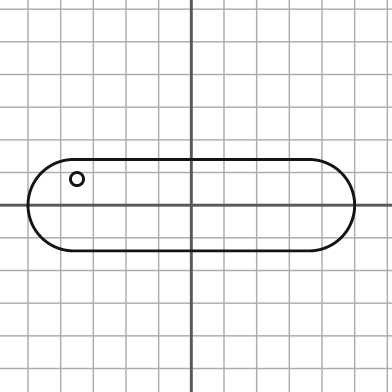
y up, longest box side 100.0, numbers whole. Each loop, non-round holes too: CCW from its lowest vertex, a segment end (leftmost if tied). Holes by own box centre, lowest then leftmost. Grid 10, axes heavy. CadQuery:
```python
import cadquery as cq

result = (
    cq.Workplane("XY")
    .moveTo(-36.0, -14.0)
    .lineTo(36.0, -14.0)
    .threePointArc((50.0, 0.0), (36.0, 14.0))
    .lineTo(-36.0, 14.0)
    .threePointArc((-50.0, 0.0), (-36.0, -14.0))
    .close()
    .moveTo(-35.0, 8.0)
    .circle(2.0)
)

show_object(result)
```